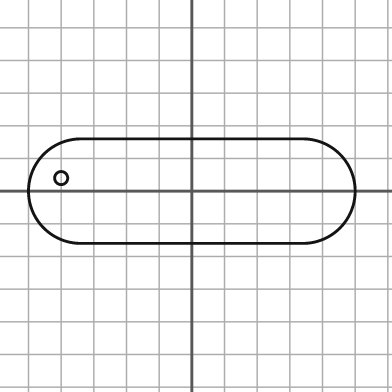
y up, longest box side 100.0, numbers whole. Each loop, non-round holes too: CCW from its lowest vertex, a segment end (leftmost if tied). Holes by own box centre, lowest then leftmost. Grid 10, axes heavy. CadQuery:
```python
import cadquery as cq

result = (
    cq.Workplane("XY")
    .moveTo(-34.0, -16.0)
    .lineTo(34.0, -16.0)
    .threePointArc((50.0, 0.0), (34.0, 16.0))
    .lineTo(-34.0, 16.0)
    .threePointArc((-50.0, 0.0), (-34.0, -16.0))
    .close()
    .moveTo(-40.0, 4.0)
    .circle(2.0)
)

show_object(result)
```